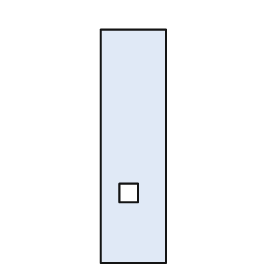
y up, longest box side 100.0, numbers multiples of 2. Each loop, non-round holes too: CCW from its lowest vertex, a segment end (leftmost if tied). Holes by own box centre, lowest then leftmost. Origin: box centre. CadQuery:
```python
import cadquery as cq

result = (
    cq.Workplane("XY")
    .moveTo(-14.0, -50.0)
    .lineTo(14.0, -50.0)
    .lineTo(14.0, 50.0)
    .lineTo(-14.0, 50.0)
    .close()
    .moveTo(-6.0, -24.0)
    .lineTo(2.0, -24.0)
    .lineTo(2.0, -16.0)
    .lineTo(-6.0, -16.0)
    .close()
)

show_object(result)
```